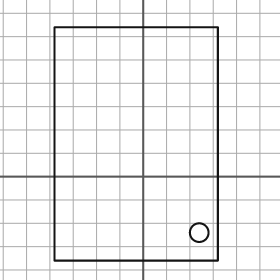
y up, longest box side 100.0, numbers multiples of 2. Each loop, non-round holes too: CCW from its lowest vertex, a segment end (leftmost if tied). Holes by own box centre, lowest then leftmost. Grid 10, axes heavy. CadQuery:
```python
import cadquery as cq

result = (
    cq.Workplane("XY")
    .moveTo(-38.0, -36.0)
    .lineTo(32.0, -36.0)
    .lineTo(32.0, 64.0)
    .lineTo(-38.0, 64.0)
    .close()
    .moveTo(24.0, -24.0)
    .circle(4.0)
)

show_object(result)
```